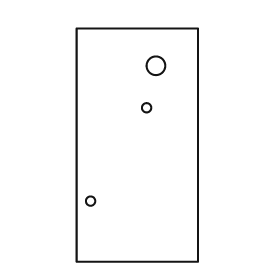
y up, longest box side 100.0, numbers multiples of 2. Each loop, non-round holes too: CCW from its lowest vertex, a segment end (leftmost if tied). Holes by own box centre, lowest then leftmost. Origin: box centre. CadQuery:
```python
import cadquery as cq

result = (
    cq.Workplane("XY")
    .moveTo(-26.0, -50.0)
    .lineTo(26.0, -50.0)
    .lineTo(26.0, 50.0)
    .lineTo(-26.0, 50.0)
    .close()
    .moveTo(-20.0, -24.0)
    .circle(2.0)
    .moveTo(4.0, 16.0)
    .circle(2.0)
    .moveTo(8.0, 34.0)
    .circle(4.0)
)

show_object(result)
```